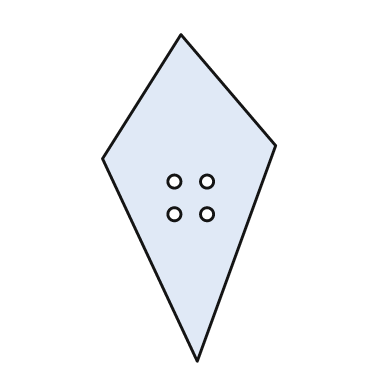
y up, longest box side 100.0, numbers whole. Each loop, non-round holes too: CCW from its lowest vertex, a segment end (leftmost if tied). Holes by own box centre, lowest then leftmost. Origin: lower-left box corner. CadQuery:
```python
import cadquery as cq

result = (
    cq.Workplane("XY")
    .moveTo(29.0, 0.0)
    .lineTo(53.0, 66.0)
    .lineTo(24.0, 100.0)
    .lineTo(0.0, 62.0)
    .close()
    .moveTo(22.0, 45.0)
    .circle(2.0)
    .moveTo(32.0, 45.0)
    .circle(2.0)
    .moveTo(22.0, 55.0)
    .circle(2.0)
    .moveTo(32.0, 55.0)
    .circle(2.0)
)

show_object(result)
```